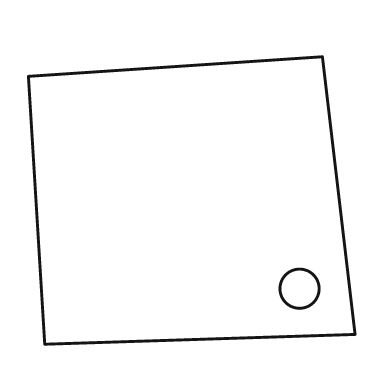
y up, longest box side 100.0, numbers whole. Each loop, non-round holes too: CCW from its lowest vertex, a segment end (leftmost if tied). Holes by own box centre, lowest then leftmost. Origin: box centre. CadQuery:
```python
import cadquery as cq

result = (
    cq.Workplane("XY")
    .moveTo(-45.0, -44.0)
    .lineTo(50.0, -41.0)
    .lineTo(40.0, 44.0)
    .lineTo(-50.0, 38.0)
    .close()
    .moveTo(33.0, -27.0)
    .circle(6.0)
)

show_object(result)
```